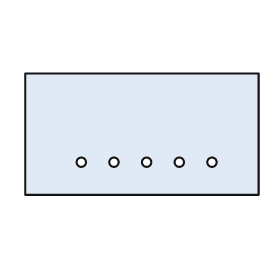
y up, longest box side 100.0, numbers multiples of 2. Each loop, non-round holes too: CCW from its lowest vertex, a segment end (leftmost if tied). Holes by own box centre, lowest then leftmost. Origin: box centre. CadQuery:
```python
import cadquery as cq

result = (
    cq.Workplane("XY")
    .moveTo(-50.0, -26.0)
    .lineTo(50.0, -26.0)
    .lineTo(50.0, 26.0)
    .lineTo(-50.0, 26.0)
    .close()
    .moveTo(-26.0, -12.0)
    .circle(2.0)
    .moveTo(-12.0, -12.0)
    .circle(2.0)
    .moveTo(2.0, -12.0)
    .circle(2.0)
    .moveTo(16.0, -12.0)
    .circle(2.0)
    .moveTo(30.0, -12.0)
    .circle(2.0)
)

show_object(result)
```